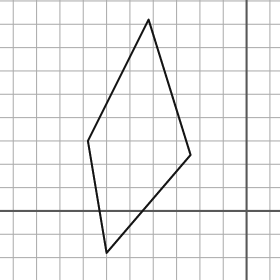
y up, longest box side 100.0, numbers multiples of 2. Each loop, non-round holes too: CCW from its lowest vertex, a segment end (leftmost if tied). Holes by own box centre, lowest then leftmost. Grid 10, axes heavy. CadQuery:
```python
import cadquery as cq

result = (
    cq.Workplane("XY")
    .moveTo(-60.0, -18.0)
    .lineTo(-24.0, 24.0)
    .lineTo(-42.0, 82.0)
    .lineTo(-68.0, 30.0)
    .close()
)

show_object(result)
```